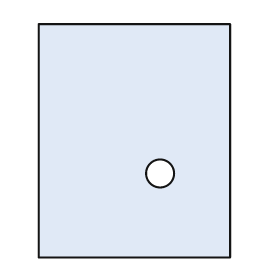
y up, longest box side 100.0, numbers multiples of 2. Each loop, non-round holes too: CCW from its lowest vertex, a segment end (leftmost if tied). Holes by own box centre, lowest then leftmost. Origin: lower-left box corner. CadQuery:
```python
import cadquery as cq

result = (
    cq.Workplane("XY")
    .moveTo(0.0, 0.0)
    .lineTo(82.0, 0.0)
    .lineTo(82.0, 100.0)
    .lineTo(0.0, 100.0)
    .close()
    .moveTo(52.0, 36.0)
    .circle(6.0)
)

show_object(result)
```